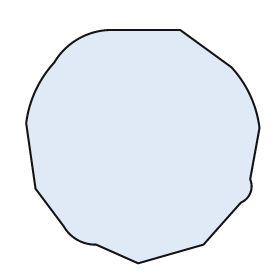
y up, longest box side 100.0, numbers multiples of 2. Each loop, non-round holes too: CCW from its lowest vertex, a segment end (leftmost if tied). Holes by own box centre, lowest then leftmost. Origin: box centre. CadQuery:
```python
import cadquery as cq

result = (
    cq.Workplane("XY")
    .moveTo(-2.0, -50.0)
    .lineTo(26.0, -42.0)
    .lineTo(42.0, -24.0)
    .threePointArc((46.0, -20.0), (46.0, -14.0))
    .lineTo(50.0, 8.0)
    .threePointArc((46.0, 22.0), (38.0, 34.0))
    .lineTo(16.0, 50.0)
    .lineTo(-14.0, 50.0)
    .threePointArc((-28.0, 46.0), (-38.0, 36.0))
    .threePointArc((-46.0, 24.0), (-50.0, 10.0))
    .lineTo(-46.0, -18.0)
    .lineTo(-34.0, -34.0)
    .threePointArc((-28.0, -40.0), (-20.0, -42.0))
    .close()
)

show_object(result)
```